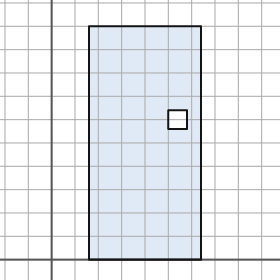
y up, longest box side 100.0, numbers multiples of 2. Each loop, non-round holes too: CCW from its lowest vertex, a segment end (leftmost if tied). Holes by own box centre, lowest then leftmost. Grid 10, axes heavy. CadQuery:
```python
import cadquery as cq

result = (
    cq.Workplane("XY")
    .moveTo(16.0, 0.0)
    .lineTo(64.0, 0.0)
    .lineTo(64.0, 100.0)
    .lineTo(16.0, 100.0)
    .close()
    .moveTo(50.0, 56.0)
    .lineTo(58.0, 56.0)
    .lineTo(58.0, 64.0)
    .lineTo(50.0, 64.0)
    .close()
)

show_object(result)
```